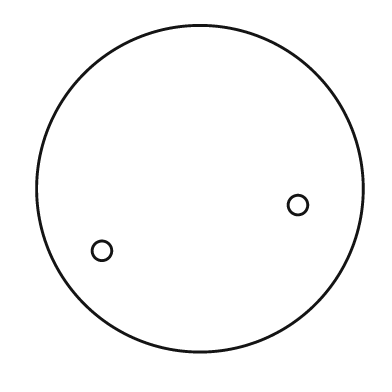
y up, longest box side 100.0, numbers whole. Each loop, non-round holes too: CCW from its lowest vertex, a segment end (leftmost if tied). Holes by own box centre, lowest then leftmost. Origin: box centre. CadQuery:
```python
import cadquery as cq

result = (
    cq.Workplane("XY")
    .moveTo(0.0, 0.0)
    .circle(50.0)
    .moveTo(-30.0, -19.0)
    .circle(3.0)
    .moveTo(30.0, -5.0)
    .circle(3.0)
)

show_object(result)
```